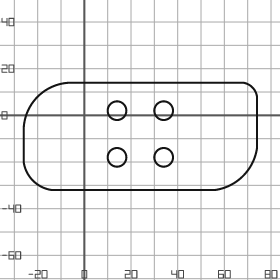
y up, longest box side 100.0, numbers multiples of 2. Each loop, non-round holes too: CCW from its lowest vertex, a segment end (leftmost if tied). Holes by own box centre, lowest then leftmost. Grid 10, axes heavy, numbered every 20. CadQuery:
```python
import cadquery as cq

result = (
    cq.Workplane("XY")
    .moveTo(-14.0, -32.0)
    .lineTo(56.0, -32.0)
    .threePointArc((68.0, -26.0), (74.0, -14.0))
    .lineTo(74.0, 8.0)
    .threePointArc((72.0, 12.0), (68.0, 14.0))
    .lineTo(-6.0, 14.0)
    .threePointArc((-20.0, 8.0), (-26.0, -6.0))
    .lineTo(-26.0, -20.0)
    .threePointArc((-22.0, -28.0), (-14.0, -32.0))
    .close()
    .moveTo(14.0, -18.0)
    .circle(4.0)
    .moveTo(34.0, -18.0)
    .circle(4.0)
    .moveTo(14.0, 2.0)
    .circle(4.0)
    .moveTo(34.0, 2.0)
    .circle(4.0)
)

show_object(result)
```